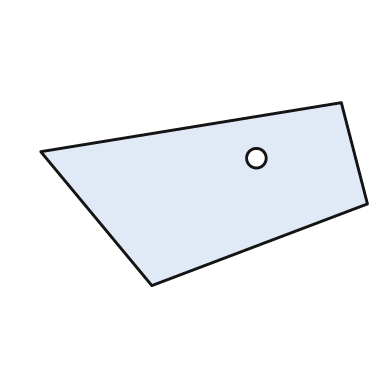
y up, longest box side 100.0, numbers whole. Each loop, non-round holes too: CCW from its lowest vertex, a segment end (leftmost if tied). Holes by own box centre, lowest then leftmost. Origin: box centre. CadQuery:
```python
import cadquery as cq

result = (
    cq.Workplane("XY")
    .moveTo(-16.0, -28.0)
    .lineTo(50.0, -3.0)
    .lineTo(42.0, 28.0)
    .lineTo(-50.0, 13.0)
    .close()
    .moveTo(16.0, 11.0)
    .circle(3.0)
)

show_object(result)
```